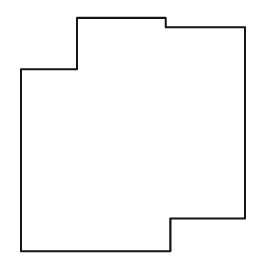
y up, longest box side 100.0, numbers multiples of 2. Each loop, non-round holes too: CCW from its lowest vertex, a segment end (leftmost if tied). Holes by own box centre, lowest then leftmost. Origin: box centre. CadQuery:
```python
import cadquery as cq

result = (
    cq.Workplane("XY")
    .moveTo(-48.0, -50.0)
    .lineTo(16.0, -50.0)
    .lineTo(16.0, -36.0)
    .lineTo(48.0, -36.0)
    .lineTo(48.0, 46.0)
    .lineTo(14.0, 46.0)
    .lineTo(14.0, 50.0)
    .lineTo(-24.0, 50.0)
    .lineTo(-24.0, 28.0)
    .lineTo(-48.0, 28.0)
    .close()
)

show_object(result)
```